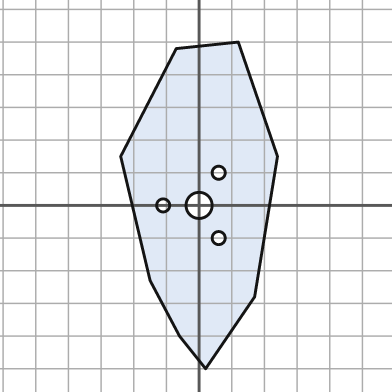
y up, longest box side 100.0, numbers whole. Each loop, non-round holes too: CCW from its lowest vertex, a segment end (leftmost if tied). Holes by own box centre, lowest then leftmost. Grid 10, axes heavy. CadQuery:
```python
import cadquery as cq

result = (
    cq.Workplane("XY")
    .moveTo(2.0, -50.0)
    .lineTo(17.0, -28.0)
    .lineTo(24.0, 15.0)
    .lineTo(12.0, 50.0)
    .lineTo(-7.0, 48.0)
    .lineTo(-24.0, 15.0)
    .lineTo(-15.0, -23.0)
    .lineTo(-6.0, -40.0)
    .close()
    .moveTo(6.0, -10.0)
    .circle(2.0)
    .moveTo(-11.0, 0.0)
    .circle(2.0)
    .moveTo(0.0, 0.0)
    .circle(4.0)
    .moveTo(6.0, 10.0)
    .circle(2.0)
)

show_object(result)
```